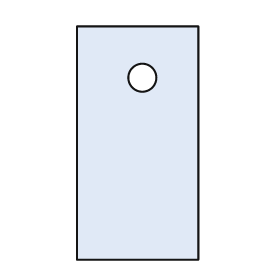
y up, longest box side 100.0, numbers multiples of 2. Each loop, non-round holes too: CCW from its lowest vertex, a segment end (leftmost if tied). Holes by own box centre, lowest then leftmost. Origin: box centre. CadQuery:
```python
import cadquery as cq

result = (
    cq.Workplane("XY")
    .moveTo(-26.0, -50.0)
    .lineTo(26.0, -50.0)
    .lineTo(26.0, 50.0)
    .lineTo(-26.0, 50.0)
    .close()
    .moveTo(2.0, 28.0)
    .circle(6.0)
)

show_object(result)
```